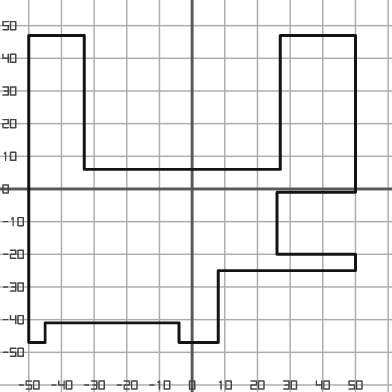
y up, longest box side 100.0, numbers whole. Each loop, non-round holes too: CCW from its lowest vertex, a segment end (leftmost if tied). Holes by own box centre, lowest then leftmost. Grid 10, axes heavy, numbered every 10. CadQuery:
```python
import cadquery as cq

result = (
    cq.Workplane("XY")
    .moveTo(-50.0, -47.0)
    .lineTo(-45.0, -47.0)
    .lineTo(-45.0, -41.0)
    .lineTo(-4.0, -41.0)
    .lineTo(-4.0, -47.0)
    .lineTo(8.0, -47.0)
    .lineTo(8.0, -25.0)
    .lineTo(50.0, -25.0)
    .lineTo(50.0, -20.0)
    .lineTo(26.0, -20.0)
    .lineTo(26.0, -1.0)
    .lineTo(50.0, -1.0)
    .lineTo(50.0, 47.0)
    .lineTo(27.0, 47.0)
    .lineTo(27.0, 6.0)
    .lineTo(-33.0, 6.0)
    .lineTo(-33.0, 47.0)
    .lineTo(-50.0, 47.0)
    .close()
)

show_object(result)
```